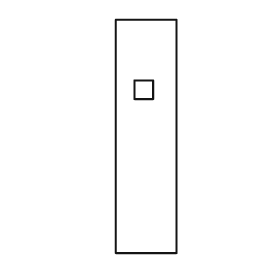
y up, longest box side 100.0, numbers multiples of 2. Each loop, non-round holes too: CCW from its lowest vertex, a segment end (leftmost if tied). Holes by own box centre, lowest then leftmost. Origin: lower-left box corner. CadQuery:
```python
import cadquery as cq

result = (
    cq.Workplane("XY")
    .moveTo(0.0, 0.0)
    .lineTo(26.0, 0.0)
    .lineTo(26.0, 100.0)
    .lineTo(0.0, 100.0)
    .close()
    .moveTo(8.0, 66.0)
    .lineTo(16.0, 66.0)
    .lineTo(16.0, 74.0)
    .lineTo(8.0, 74.0)
    .close()
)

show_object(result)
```